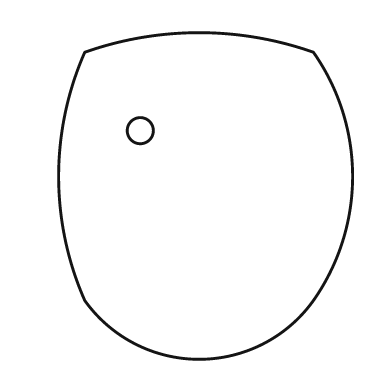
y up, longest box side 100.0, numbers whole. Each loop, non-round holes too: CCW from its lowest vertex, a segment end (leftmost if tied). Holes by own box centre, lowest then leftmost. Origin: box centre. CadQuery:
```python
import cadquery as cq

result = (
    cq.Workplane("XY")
    .moveTo(-37.0, -32.0)
    .threePointArc((-2.0, -50.0), (33.0, -32.0))
    .threePointArc((45.0, 6.0), (33.0, 44.0))
    .threePointArc((-2.0, 50.0), (-37.0, 44.0))
    .threePointArc((-45.0, 6.0), (-37.0, -32.0))
    .close()
    .moveTo(-20.0, 20.0)
    .circle(4.0)
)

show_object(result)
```